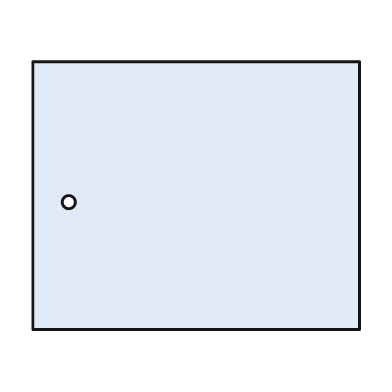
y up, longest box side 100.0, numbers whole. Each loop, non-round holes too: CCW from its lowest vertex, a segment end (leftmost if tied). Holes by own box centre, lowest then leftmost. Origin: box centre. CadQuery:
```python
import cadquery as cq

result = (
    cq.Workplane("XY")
    .moveTo(-50.0, -41.0)
    .lineTo(50.0, -41.0)
    .lineTo(50.0, 41.0)
    .lineTo(-50.0, 41.0)
    .close()
    .moveTo(-39.0, -2.0)
    .circle(2.0)
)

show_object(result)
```